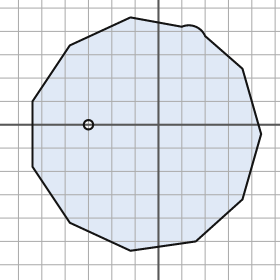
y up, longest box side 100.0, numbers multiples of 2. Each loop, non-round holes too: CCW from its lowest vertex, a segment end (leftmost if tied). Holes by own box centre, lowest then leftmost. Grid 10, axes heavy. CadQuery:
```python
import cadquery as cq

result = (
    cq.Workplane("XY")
    .moveTo(-12.0, -54.0)
    .lineTo(16.0, -50.0)
    .lineTo(36.0, -32.0)
    .lineTo(44.0, -4.0)
    .lineTo(36.0, 24.0)
    .lineTo(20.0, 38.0)
    .threePointArc((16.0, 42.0), (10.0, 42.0))
    .lineTo(-12.0, 46.0)
    .lineTo(-38.0, 34.0)
    .lineTo(-54.0, 10.0)
    .lineTo(-54.0, -18.0)
    .lineTo(-38.0, -42.0)
    .close()
    .moveTo(-30.0, 0.0)
    .circle(2.0)
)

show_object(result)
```